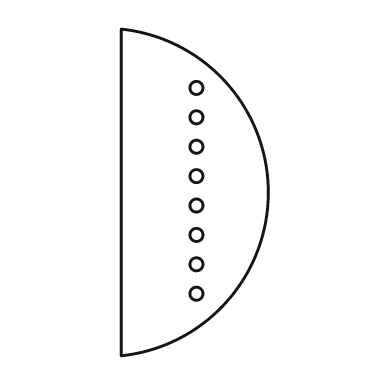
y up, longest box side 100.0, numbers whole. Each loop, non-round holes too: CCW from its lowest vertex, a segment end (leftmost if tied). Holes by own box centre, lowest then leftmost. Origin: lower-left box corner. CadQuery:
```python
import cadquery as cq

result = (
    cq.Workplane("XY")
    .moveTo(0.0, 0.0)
    .threePointArc((45.0, 50.0), (0.0, 100.0))
    .close()
    .moveTo(23.0, 19.0)
    .circle(2.0)
    .moveTo(23.0, 28.0)
    .circle(2.0)
    .moveTo(23.0, 37.0)
    .circle(2.0)
    .moveTo(23.0, 46.0)
    .circle(2.0)
    .moveTo(23.0, 55.0)
    .circle(2.0)
    .moveTo(23.0, 64.0)
    .circle(2.0)
    .moveTo(23.0, 73.0)
    .circle(2.0)
    .moveTo(23.0, 82.0)
    .circle(2.0)
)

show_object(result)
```